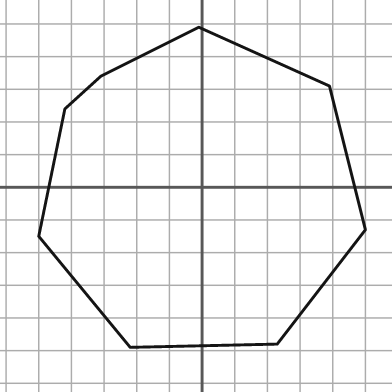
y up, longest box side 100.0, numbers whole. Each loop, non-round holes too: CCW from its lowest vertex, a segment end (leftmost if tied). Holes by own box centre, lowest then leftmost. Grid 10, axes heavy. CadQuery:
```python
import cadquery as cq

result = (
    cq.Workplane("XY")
    .moveTo(-22.0, -49.0)
    .lineTo(23.0, -48.0)
    .lineTo(50.0, -13.0)
    .lineTo(39.0, 31.0)
    .lineTo(-1.0, 49.0)
    .lineTo(-31.0, 34.0)
    .lineTo(-42.0, 24.0)
    .lineTo(-50.0, -15.0)
    .close()
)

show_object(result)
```